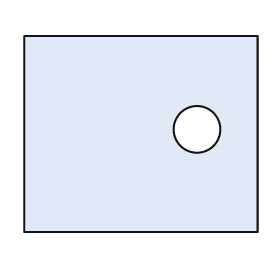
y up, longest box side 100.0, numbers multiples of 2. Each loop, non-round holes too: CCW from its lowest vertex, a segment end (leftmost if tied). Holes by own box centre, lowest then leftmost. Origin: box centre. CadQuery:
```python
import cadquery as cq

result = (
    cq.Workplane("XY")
    .moveTo(-50.0, -42.0)
    .lineTo(50.0, -42.0)
    .lineTo(50.0, 42.0)
    .lineTo(-50.0, 42.0)
    .close()
    .moveTo(24.0, 2.0)
    .circle(10.0)
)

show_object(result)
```